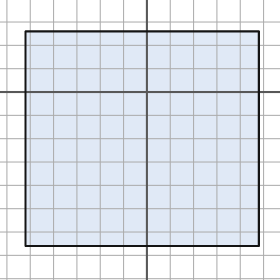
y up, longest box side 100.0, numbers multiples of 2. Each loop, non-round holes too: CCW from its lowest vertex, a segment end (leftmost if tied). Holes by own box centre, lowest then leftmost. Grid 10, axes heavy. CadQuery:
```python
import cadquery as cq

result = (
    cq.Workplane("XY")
    .moveTo(-52.0, -66.0)
    .lineTo(48.0, -66.0)
    .lineTo(48.0, 26.0)
    .lineTo(-52.0, 26.0)
    .close()
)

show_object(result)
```